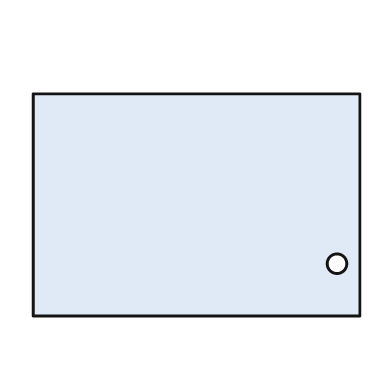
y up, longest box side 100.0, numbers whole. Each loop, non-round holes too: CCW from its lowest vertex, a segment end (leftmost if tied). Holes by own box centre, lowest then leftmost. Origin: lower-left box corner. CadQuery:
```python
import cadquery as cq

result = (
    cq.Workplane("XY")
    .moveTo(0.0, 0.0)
    .lineTo(100.0, 0.0)
    .lineTo(100.0, 68.0)
    .lineTo(0.0, 68.0)
    .close()
    .moveTo(93.0, 16.0)
    .circle(3.0)
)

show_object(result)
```